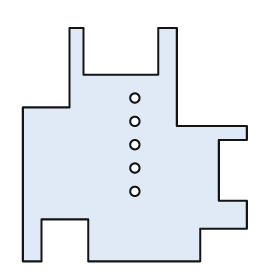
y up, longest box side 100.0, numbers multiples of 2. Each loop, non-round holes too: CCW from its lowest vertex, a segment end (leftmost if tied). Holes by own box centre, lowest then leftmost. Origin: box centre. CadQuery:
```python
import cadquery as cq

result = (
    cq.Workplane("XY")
    .moveTo(-48.0, -50.0)
    .lineTo(-40.0, -50.0)
    .lineTo(-40.0, -32.0)
    .lineTo(-20.0, -32.0)
    .lineTo(-20.0, -50.0)
    .lineTo(28.0, -50.0)
    .lineTo(28.0, -36.0)
    .lineTo(48.0, -36.0)
    .lineTo(48.0, -24.0)
    .lineTo(36.0, -24.0)
    .lineTo(36.0, 2.0)
    .lineTo(48.0, 2.0)
    .lineTo(48.0, 8.0)
    .lineTo(18.0, 8.0)
    .lineTo(18.0, 50.0)
    .lineTo(10.0, 50.0)
    .lineTo(10.0, 30.0)
    .lineTo(-22.0, 30.0)
    .lineTo(-22.0, 50.0)
    .lineTo(-28.0, 50.0)
    .lineTo(-28.0, 16.0)
    .lineTo(-48.0, 16.0)
    .close()
    .moveTo(0.0, -20.0)
    .circle(2.0)
    .moveTo(0.0, -10.0)
    .circle(2.0)
    .moveTo(0.0, 0.0)
    .circle(2.0)
    .moveTo(0.0, 10.0)
    .circle(2.0)
    .moveTo(0.0, 20.0)
    .circle(2.0)
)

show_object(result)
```